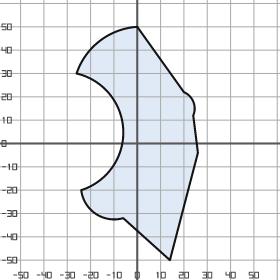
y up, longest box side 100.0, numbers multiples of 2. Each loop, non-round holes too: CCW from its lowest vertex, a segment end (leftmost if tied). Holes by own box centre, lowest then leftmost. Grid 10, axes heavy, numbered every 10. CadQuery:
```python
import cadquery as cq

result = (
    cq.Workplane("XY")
    .moveTo(14.0, -50.0)
    .lineTo(26.0, -4.0)
    .lineTo(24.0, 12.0)
    .threePointArc((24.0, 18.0), (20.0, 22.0))
    .lineTo(0.0, 50.0)
    .threePointArc((-16.0, 44.0), (-26.0, 30.0))
    .threePointArc((-6.0, 6.0), (-24.0, -20.0))
    .threePointArc((-18.0, -30.0), (-6.0, -32.0))
    .close()
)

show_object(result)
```